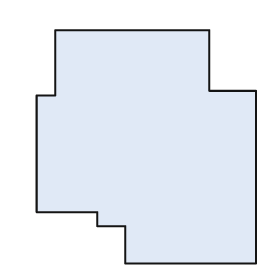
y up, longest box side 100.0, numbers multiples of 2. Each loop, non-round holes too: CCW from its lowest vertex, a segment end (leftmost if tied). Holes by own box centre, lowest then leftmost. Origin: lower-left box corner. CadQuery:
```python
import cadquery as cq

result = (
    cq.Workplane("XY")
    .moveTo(38.0, 0.0)
    .lineTo(94.0, 0.0)
    .lineTo(94.0, 74.0)
    .lineTo(74.0, 74.0)
    .lineTo(74.0, 100.0)
    .lineTo(8.0, 100.0)
    .lineTo(8.0, 72.0)
    .lineTo(0.0, 72.0)
    .lineTo(0.0, 22.0)
    .lineTo(26.0, 22.0)
    .lineTo(26.0, 16.0)
    .lineTo(38.0, 16.0)
    .close()
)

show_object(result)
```